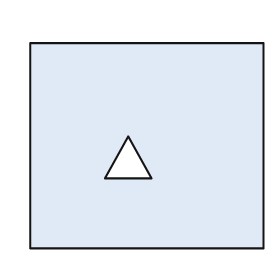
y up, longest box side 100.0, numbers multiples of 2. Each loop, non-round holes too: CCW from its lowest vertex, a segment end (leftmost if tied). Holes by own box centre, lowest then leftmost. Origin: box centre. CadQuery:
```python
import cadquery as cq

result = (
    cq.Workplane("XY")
    .moveTo(-50.0, -44.0)
    .lineTo(50.0, -44.0)
    .lineTo(50.0, 44.0)
    .lineTo(-50.0, 44.0)
    .close()
    .moveTo(-18.0, -14.0)
    .lineTo(2.0, -14.0)
    .lineTo(-8.0, 4.0)
    .close()
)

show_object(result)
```